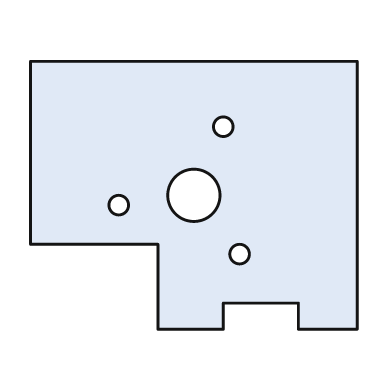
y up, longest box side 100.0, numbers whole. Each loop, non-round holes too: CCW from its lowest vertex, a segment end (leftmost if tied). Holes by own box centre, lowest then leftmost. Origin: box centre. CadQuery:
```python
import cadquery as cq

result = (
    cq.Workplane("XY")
    .moveTo(-11.0, -41.0)
    .lineTo(9.0, -41.0)
    .lineTo(9.0, -33.0)
    .lineTo(32.0, -33.0)
    .lineTo(32.0, -41.0)
    .lineTo(50.0, -41.0)
    .lineTo(50.0, 41.0)
    .lineTo(-50.0, 41.0)
    .lineTo(-50.0, -15.0)
    .lineTo(-11.0, -15.0)
    .close()
    .moveTo(14.0, -18.0)
    .circle(3.0)
    .moveTo(-23.0, -3.0)
    .circle(3.0)
    .moveTo(0.0, 0.0)
    .circle(8.0)
    .moveTo(9.0, 21.0)
    .circle(3.0)
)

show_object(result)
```